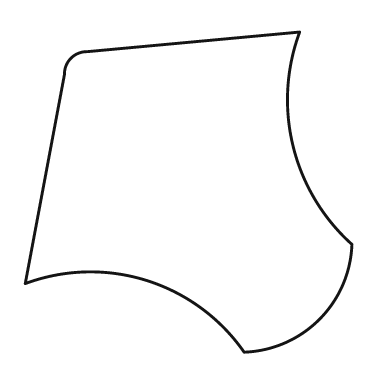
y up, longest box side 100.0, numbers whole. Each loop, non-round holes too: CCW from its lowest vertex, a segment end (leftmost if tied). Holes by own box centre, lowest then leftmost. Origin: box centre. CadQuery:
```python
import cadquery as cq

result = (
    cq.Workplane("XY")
    .moveTo(17.0, -49.0)
    .threePointArc((40.0, -39.0), (50.0, -16.0))
    .threePointArc((32.0, 14.0), (34.0, 49.0))
    .lineTo(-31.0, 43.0)
    .threePointArc((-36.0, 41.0), (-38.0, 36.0))
    .lineTo(-50.0, -28.0)
    .threePointArc((-13.0, -27.0), (17.0, -49.0))
    .close()
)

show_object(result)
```